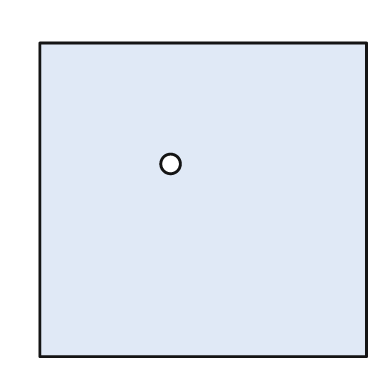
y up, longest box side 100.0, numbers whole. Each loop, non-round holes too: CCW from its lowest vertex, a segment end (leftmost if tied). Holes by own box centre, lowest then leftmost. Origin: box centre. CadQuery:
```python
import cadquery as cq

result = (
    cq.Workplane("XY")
    .moveTo(-50.0, -48.0)
    .lineTo(50.0, -48.0)
    .lineTo(50.0, 48.0)
    .lineTo(-50.0, 48.0)
    .close()
    .moveTo(-10.0, 11.0)
    .circle(3.0)
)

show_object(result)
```